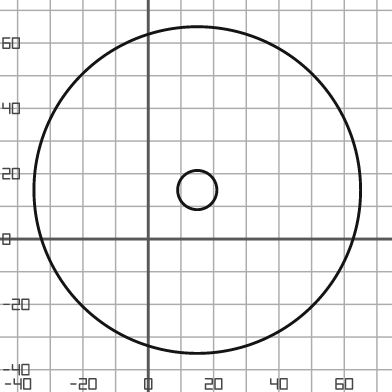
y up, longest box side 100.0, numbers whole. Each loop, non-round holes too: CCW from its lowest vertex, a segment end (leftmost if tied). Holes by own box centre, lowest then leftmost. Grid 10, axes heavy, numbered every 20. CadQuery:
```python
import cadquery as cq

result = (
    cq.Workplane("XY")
    .moveTo(15.0, 15.0)
    .circle(50.0)
    .moveTo(15.0, 15.0)
    .circle(6.0)
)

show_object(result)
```